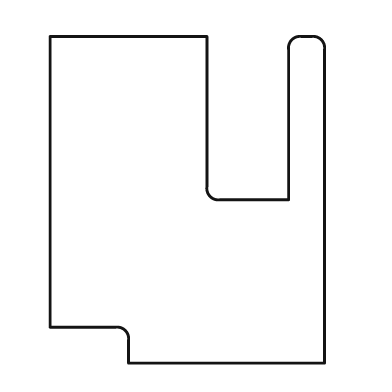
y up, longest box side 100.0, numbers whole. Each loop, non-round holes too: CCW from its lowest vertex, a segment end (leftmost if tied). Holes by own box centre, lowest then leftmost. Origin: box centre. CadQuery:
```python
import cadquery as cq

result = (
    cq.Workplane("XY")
    .moveTo(-18.0, -50.0)
    .lineTo(42.0, -50.0)
    .lineTo(42.0, 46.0)
    .threePointArc((41.0, 49.0), (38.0, 50.0))
    .lineTo(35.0, 50.0)
    .threePointArc((32.0, 49.0), (31.0, 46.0))
    .lineTo(31.0, 0.0)
    .lineTo(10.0, 0.0)
    .threePointArc((7.0, 1.0), (6.0, 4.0))
    .lineTo(6.0, 50.0)
    .lineTo(-42.0, 50.0)
    .lineTo(-42.0, -39.0)
    .lineTo(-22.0, -39.0)
    .threePointArc((-19.0, -40.0), (-18.0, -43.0))
    .close()
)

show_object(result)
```